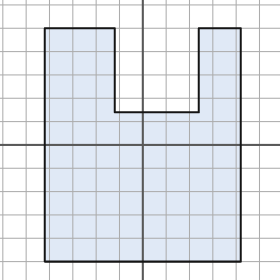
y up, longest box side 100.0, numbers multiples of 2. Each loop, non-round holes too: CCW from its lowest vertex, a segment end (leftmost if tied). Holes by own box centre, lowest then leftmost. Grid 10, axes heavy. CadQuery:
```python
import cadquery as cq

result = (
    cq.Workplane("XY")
    .moveTo(-42.0, -50.0)
    .lineTo(42.0, -50.0)
    .lineTo(42.0, 50.0)
    .lineTo(24.0, 50.0)
    .lineTo(24.0, 14.0)
    .lineTo(-12.0, 14.0)
    .lineTo(-12.0, 50.0)
    .lineTo(-42.0, 50.0)
    .close()
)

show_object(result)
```